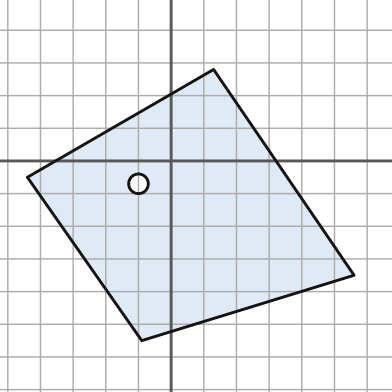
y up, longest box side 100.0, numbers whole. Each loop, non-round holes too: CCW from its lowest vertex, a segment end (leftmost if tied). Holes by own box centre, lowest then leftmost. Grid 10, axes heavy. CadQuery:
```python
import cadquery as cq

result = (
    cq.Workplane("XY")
    .moveTo(-9.0, -55.0)
    .lineTo(56.0, -35.0)
    .lineTo(13.0, 28.0)
    .lineTo(-44.0, -5.0)
    .close()
    .moveTo(-10.0, -7.0)
    .circle(3.0)
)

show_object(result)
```